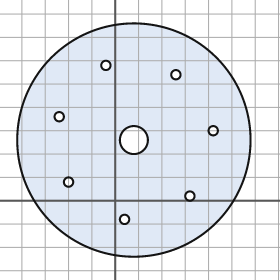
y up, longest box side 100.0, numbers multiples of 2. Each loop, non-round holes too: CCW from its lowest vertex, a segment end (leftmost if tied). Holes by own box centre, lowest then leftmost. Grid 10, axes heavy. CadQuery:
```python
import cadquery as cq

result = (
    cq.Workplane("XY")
    .moveTo(8.0, 26.0)
    .circle(50.0)
    .moveTo(4.0, -8.0)
    .circle(2.0)
    .moveTo(32.0, 2.0)
    .circle(2.0)
    .moveTo(-20.0, 8.0)
    .circle(2.0)
    .moveTo(8.0, 26.0)
    .circle(6.0)
    .moveTo(42.0, 30.0)
    .circle(2.0)
    .moveTo(-24.0, 36.0)
    .circle(2.0)
    .moveTo(26.0, 54.0)
    .circle(2.0)
    .moveTo(-4.0, 58.0)
    .circle(2.0)
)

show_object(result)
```